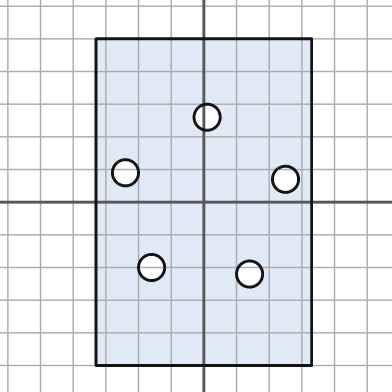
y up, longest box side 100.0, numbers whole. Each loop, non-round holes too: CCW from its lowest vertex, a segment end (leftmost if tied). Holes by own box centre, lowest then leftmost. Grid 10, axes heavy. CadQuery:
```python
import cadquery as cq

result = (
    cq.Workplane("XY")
    .moveTo(-33.0, -50.0)
    .lineTo(33.0, -50.0)
    .lineTo(33.0, 50.0)
    .lineTo(-33.0, 50.0)
    .close()
    .moveTo(14.0, -22.0)
    .circle(4.0)
    .moveTo(-16.0, -20.0)
    .circle(4.0)
    .moveTo(25.0, 7.0)
    .circle(4.0)
    .moveTo(-24.0, 9.0)
    .circle(4.0)
    .moveTo(1.0, 26.0)
    .circle(4.0)
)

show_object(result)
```